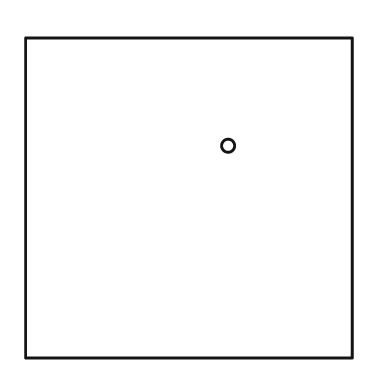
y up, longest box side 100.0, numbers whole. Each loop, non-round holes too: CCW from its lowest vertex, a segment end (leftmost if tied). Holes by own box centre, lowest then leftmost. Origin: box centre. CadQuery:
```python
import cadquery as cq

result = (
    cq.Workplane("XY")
    .moveTo(-50.0, -49.0)
    .lineTo(50.0, -49.0)
    .lineTo(50.0, 49.0)
    .lineTo(-50.0, 49.0)
    .close()
    .moveTo(12.0, 16.0)
    .circle(2.0)
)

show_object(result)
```